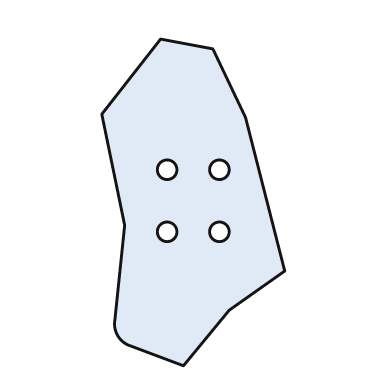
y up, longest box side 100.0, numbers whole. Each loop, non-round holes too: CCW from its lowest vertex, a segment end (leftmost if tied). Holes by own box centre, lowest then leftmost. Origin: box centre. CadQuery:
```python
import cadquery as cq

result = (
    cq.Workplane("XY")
    .moveTo(-3.0, -50.0)
    .lineTo(11.0, -33.0)
    .lineTo(28.0, -21.0)
    .lineTo(16.0, 26.0)
    .lineTo(6.0, 47.0)
    .lineTo(-10.0, 50.0)
    .lineTo(-28.0, 27.0)
    .lineTo(-21.0, -7.0)
    .lineTo(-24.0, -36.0)
    .threePointArc((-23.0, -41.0), (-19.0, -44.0))
    .close()
    .moveTo(-8.0, -9.0)
    .circle(3.0)
    .moveTo(8.0, -9.0)
    .circle(3.0)
    .moveTo(-8.0, 10.0)
    .circle(3.0)
    .moveTo(8.0, 10.0)
    .circle(3.0)
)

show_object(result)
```